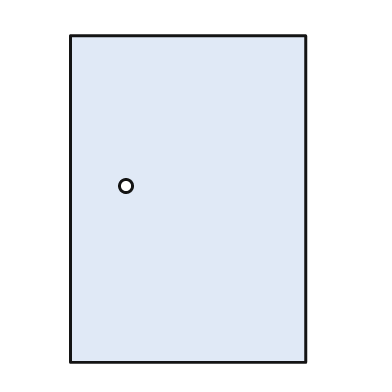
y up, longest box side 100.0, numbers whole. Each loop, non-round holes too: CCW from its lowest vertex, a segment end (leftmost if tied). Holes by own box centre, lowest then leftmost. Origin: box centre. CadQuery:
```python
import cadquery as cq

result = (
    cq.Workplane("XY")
    .moveTo(-36.0, -50.0)
    .lineTo(36.0, -50.0)
    .lineTo(36.0, 50.0)
    .lineTo(-36.0, 50.0)
    .close()
    .moveTo(-19.0, 4.0)
    .circle(2.0)
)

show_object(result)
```